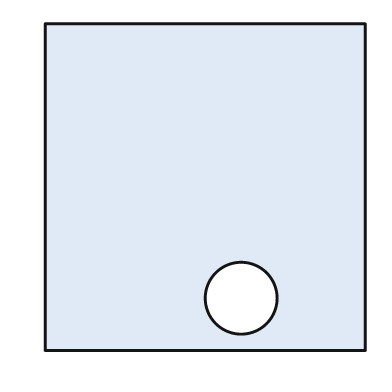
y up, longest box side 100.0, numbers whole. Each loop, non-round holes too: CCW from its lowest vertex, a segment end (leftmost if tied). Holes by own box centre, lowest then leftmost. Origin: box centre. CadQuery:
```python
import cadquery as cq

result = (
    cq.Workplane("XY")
    .moveTo(-49.0, -50.0)
    .lineTo(49.0, -50.0)
    .lineTo(49.0, 50.0)
    .lineTo(-49.0, 50.0)
    .close()
    .moveTo(11.0, -34.0)
    .circle(11.0)
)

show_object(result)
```